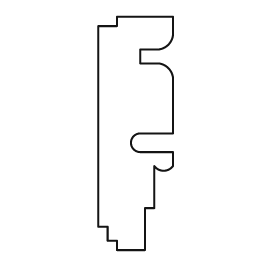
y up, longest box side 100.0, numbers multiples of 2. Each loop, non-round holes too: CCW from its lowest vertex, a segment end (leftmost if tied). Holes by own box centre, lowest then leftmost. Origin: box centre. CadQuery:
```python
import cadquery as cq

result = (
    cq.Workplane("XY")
    .moveTo(-8.0, -50.0)
    .lineTo(4.0, -50.0)
    .lineTo(4.0, -32.0)
    .lineTo(8.0, -32.0)
    .lineTo(8.0, -14.0)
    .threePointArc((12.0, -16.0), (16.0, -14.0))
    .lineTo(16.0, -8.0)
    .lineTo(2.0, -8.0)
    .threePointArc((-2.0, -4.0), (2.0, 0.0))
    .lineTo(16.0, 0.0)
    .lineTo(16.0, 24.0)
    .threePointArc((14.0, 28.0), (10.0, 30.0))
    .lineTo(2.0, 30.0)
    .lineTo(2.0, 36.0)
    .lineTo(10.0, 36.0)
    .threePointArc((14.0, 38.0), (16.0, 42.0))
    .lineTo(16.0, 50.0)
    .lineTo(-8.0, 50.0)
    .lineTo(-8.0, 46.0)
    .lineTo(-16.0, 46.0)
    .lineTo(-16.0, -40.0)
    .lineTo(-12.0, -40.0)
    .lineTo(-12.0, -46.0)
    .lineTo(-8.0, -46.0)
    .close()
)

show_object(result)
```